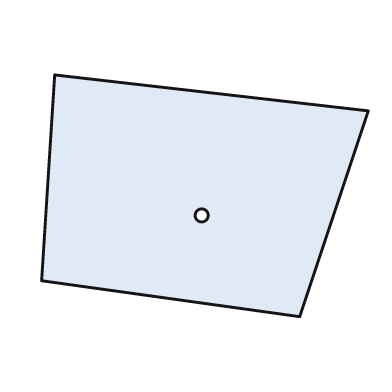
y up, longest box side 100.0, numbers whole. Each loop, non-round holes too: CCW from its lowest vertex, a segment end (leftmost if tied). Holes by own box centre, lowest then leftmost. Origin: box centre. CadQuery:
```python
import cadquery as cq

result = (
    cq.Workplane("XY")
    .moveTo(29.0, -37.0)
    .lineTo(50.0, 26.0)
    .lineTo(-46.0, 37.0)
    .lineTo(-50.0, -26.0)
    .close()
    .moveTo(-1.0, -6.0)
    .circle(2.0)
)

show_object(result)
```